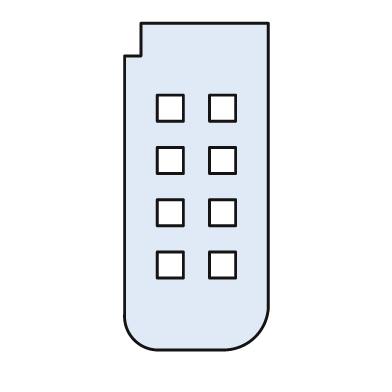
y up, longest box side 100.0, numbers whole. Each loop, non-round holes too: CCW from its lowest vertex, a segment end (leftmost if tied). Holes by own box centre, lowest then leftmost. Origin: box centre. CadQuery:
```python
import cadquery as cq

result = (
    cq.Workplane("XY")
    .moveTo(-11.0, -50.0)
    .lineTo(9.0, -50.0)
    .threePointArc((18.0, -46.0), (22.0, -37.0))
    .lineTo(22.0, 50.0)
    .lineTo(-17.0, 50.0)
    .lineTo(-17.0, 40.0)
    .lineTo(-22.0, 40.0)
    .lineTo(-22.0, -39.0)
    .threePointArc((-19.0, -47.0), (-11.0, -50.0))
    .close()
    .moveTo(-12.0, -28.0)
    .lineTo(-4.0, -28.0)
    .lineTo(-4.0, -20.0)
    .lineTo(-12.0, -20.0)
    .close()
    .moveTo(4.0, -28.0)
    .lineTo(12.0, -28.0)
    .lineTo(12.0, -20.0)
    .lineTo(4.0, -20.0)
    .close()
    .moveTo(-12.0, -12.0)
    .lineTo(-4.0, -12.0)
    .lineTo(-4.0, -4.0)
    .lineTo(-12.0, -4.0)
    .close()
    .moveTo(4.0, -12.0)
    .lineTo(12.0, -12.0)
    .lineTo(12.0, -4.0)
    .lineTo(4.0, -4.0)
    .close()
    .moveTo(-12.0, 4.0)
    .lineTo(-4.0, 4.0)
    .lineTo(-4.0, 12.0)
    .lineTo(-12.0, 12.0)
    .close()
    .moveTo(4.0, 4.0)
    .lineTo(12.0, 4.0)
    .lineTo(12.0, 12.0)
    .lineTo(4.0, 12.0)
    .close()
    .moveTo(-12.0, 20.0)
    .lineTo(-4.0, 20.0)
    .lineTo(-4.0, 28.0)
    .lineTo(-12.0, 28.0)
    .close()
    .moveTo(4.0, 20.0)
    .lineTo(12.0, 20.0)
    .lineTo(12.0, 28.0)
    .lineTo(4.0, 28.0)
    .close()
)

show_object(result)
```